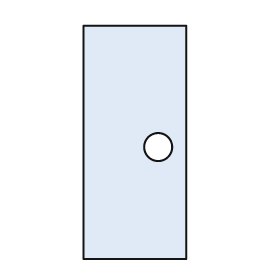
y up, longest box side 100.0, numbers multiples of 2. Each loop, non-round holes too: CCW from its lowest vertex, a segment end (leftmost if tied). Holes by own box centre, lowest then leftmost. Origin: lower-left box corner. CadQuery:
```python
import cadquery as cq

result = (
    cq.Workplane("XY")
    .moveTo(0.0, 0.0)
    .lineTo(44.0, 0.0)
    .lineTo(44.0, 100.0)
    .lineTo(0.0, 100.0)
    .close()
    .moveTo(32.0, 48.0)
    .circle(6.0)
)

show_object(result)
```